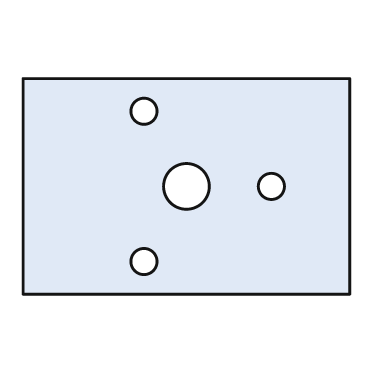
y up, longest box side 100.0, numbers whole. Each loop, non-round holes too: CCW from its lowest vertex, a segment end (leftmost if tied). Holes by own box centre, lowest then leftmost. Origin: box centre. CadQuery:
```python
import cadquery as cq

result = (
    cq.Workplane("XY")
    .moveTo(-50.0, -33.0)
    .lineTo(50.0, -33.0)
    .lineTo(50.0, 33.0)
    .lineTo(-50.0, 33.0)
    .close()
    .moveTo(-13.0, -23.0)
    .circle(4.0)
    .moveTo(0.0, 0.0)
    .circle(7.0)
    .moveTo(26.0, 0.0)
    .circle(4.0)
    .moveTo(-13.0, 23.0)
    .circle(4.0)
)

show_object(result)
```